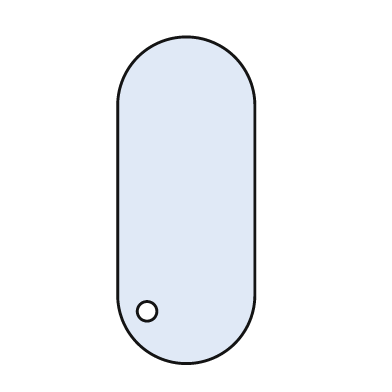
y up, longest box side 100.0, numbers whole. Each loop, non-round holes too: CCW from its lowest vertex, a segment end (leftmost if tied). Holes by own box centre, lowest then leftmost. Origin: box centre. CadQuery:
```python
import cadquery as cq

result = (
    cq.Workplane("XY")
    .moveTo(-21.0, -29.0)
    .threePointArc((0.0, -50.0), (21.0, -29.0))
    .lineTo(21.0, 29.0)
    .threePointArc((0.0, 50.0), (-21.0, 29.0))
    .close()
    .moveTo(-12.0, -34.0)
    .circle(3.0)
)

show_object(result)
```